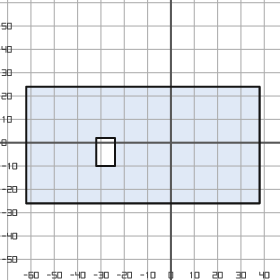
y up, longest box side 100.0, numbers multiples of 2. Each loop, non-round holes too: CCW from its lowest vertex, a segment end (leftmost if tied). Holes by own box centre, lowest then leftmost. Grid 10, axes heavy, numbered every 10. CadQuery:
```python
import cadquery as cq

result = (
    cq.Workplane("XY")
    .moveTo(-62.0, -26.0)
    .lineTo(38.0, -26.0)
    .lineTo(38.0, 24.0)
    .lineTo(-62.0, 24.0)
    .close()
    .moveTo(-32.0, -10.0)
    .lineTo(-24.0, -10.0)
    .lineTo(-24.0, 2.0)
    .lineTo(-32.0, 2.0)
    .close()
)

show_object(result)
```